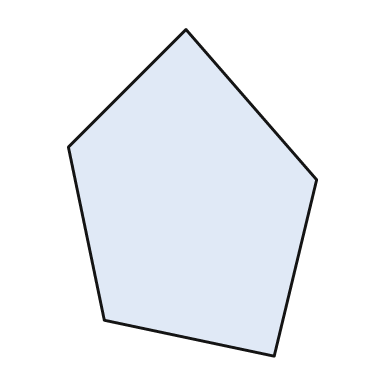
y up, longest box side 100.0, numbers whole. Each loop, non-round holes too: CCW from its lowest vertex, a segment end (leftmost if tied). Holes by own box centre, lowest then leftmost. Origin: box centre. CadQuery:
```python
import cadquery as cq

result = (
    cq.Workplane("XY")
    .moveTo(25.0, -50.0)
    .lineTo(38.0, 4.0)
    .lineTo(-2.0, 50.0)
    .lineTo(-38.0, 14.0)
    .lineTo(-27.0, -39.0)
    .close()
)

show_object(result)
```